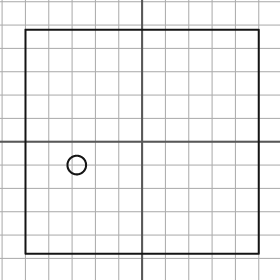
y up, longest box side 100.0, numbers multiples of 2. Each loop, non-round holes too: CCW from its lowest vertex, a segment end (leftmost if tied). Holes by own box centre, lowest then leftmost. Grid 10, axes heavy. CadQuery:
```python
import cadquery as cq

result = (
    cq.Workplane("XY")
    .moveTo(-50.0, -48.0)
    .lineTo(50.0, -48.0)
    .lineTo(50.0, 48.0)
    .lineTo(-50.0, 48.0)
    .close()
    .moveTo(-28.0, -10.0)
    .circle(4.0)
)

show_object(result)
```